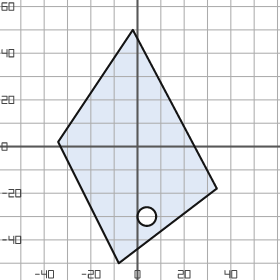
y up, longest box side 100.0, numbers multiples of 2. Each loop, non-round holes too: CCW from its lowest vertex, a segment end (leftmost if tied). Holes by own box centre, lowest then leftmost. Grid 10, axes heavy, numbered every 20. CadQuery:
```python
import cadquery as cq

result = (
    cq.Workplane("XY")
    .moveTo(-8.0, -50.0)
    .lineTo(34.0, -18.0)
    .lineTo(-2.0, 50.0)
    .lineTo(-34.0, 2.0)
    .close()
    .moveTo(4.0, -30.0)
    .circle(4.0)
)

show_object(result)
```